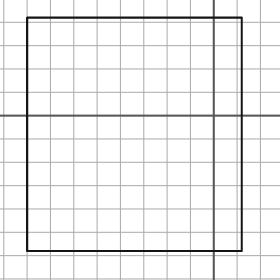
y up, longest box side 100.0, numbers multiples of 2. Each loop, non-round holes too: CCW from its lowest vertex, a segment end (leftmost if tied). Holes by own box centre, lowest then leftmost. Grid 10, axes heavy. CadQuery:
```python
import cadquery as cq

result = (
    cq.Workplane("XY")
    .moveTo(-80.0, -58.0)
    .lineTo(12.0, -58.0)
    .lineTo(12.0, 42.0)
    .lineTo(-80.0, 42.0)
    .close()
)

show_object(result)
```